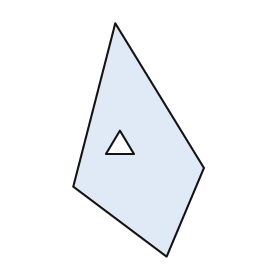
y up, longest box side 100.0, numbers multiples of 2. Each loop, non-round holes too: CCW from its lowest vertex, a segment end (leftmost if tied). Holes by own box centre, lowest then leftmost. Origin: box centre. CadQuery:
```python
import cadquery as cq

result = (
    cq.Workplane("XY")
    .moveTo(12.0, -50.0)
    .lineTo(28.0, -12.0)
    .lineTo(-10.0, 50.0)
    .lineTo(-28.0, -20.0)
    .close()
    .moveTo(-14.0, -6.0)
    .lineTo(-2.0, -6.0)
    .lineTo(-8.0, 4.0)
    .close()
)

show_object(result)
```